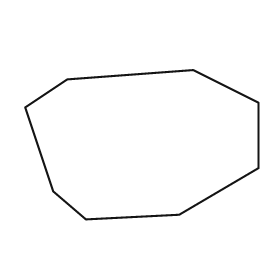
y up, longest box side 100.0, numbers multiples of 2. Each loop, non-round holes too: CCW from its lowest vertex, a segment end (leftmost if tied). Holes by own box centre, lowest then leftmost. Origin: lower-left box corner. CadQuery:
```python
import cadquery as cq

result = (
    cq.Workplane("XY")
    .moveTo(26.0, 0.0)
    .lineTo(66.0, 2.0)
    .lineTo(100.0, 22.0)
    .lineTo(100.0, 50.0)
    .lineTo(72.0, 64.0)
    .lineTo(18.0, 60.0)
    .lineTo(0.0, 48.0)
    .lineTo(12.0, 12.0)
    .close()
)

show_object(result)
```